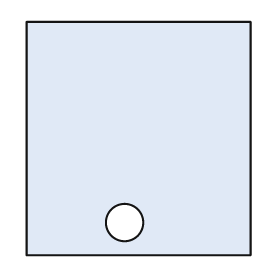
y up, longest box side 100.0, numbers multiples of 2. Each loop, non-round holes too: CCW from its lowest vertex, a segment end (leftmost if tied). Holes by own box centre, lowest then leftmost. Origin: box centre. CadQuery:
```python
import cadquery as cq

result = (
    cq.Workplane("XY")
    .moveTo(-48.0, -50.0)
    .lineTo(48.0, -50.0)
    .lineTo(48.0, 50.0)
    .lineTo(-48.0, 50.0)
    .close()
    .moveTo(-6.0, -36.0)
    .circle(8.0)
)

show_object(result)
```